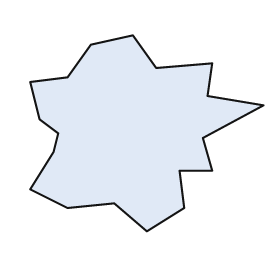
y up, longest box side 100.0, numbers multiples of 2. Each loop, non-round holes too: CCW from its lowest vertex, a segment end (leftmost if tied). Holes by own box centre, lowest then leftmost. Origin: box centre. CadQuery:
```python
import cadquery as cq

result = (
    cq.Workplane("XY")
    .moveTo(0.0, -42.0)
    .lineTo(16.0, -32.0)
    .lineTo(14.0, -16.0)
    .lineTo(28.0, -16.0)
    .lineTo(24.0, -2.0)
    .lineTo(50.0, 12.0)
    .lineTo(26.0, 16.0)
    .lineTo(28.0, 30.0)
    .lineTo(4.0, 28.0)
    .lineTo(-6.0, 42.0)
    .lineTo(-24.0, 38.0)
    .lineTo(-34.0, 24.0)
    .lineTo(-50.0, 22.0)
    .lineTo(-46.0, 6.0)
    .lineTo(-38.0, 0.0)
    .lineTo(-40.0, -8.0)
    .lineTo(-50.0, -24.0)
    .lineTo(-34.0, -32.0)
    .lineTo(-14.0, -30.0)
    .close()
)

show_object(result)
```